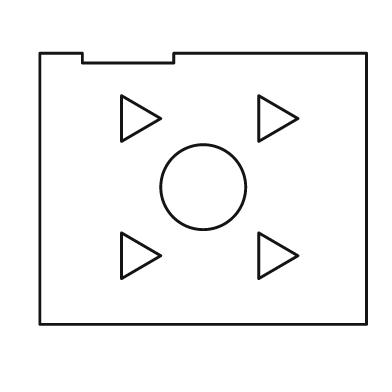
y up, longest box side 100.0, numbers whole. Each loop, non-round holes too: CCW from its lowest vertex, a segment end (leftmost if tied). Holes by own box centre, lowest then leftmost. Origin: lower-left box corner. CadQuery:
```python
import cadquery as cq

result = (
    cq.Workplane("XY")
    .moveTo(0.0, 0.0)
    .lineTo(100.0, 0.0)
    .lineTo(100.0, 83.0)
    .lineTo(41.0, 83.0)
    .lineTo(41.0, 80.0)
    .lineTo(13.0, 80.0)
    .lineTo(13.0, 83.0)
    .lineTo(0.0, 83.0)
    .close()
    .moveTo(25.0, 14.0)
    .lineTo(37.0, 21.0)
    .lineTo(25.0, 28.0)
    .close()
    .moveTo(67.0, 14.0)
    .lineTo(79.0, 21.0)
    .lineTo(67.0, 28.0)
    .close()
    .moveTo(50.0, 42.0)
    .circle(13.0)
    .moveTo(25.0, 56.0)
    .lineTo(37.0, 63.0)
    .lineTo(25.0, 70.0)
    .close()
    .moveTo(67.0, 56.0)
    .lineTo(79.0, 63.0)
    .lineTo(67.0, 70.0)
    .close()
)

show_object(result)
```